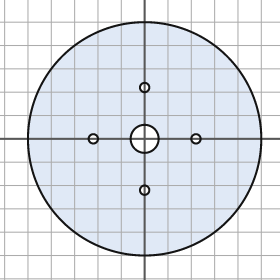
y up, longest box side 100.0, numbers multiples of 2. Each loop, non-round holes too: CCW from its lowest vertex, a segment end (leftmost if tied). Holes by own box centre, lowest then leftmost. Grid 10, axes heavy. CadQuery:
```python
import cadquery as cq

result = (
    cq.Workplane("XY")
    .moveTo(0.0, 0.0)
    .circle(50.0)
    .moveTo(0.0, -22.0)
    .circle(2.0)
    .moveTo(-22.0, 0.0)
    .circle(2.0)
    .moveTo(0.0, 0.0)
    .circle(6.0)
    .moveTo(22.0, 0.0)
    .circle(2.0)
    .moveTo(0.0, 22.0)
    .circle(2.0)
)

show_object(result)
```